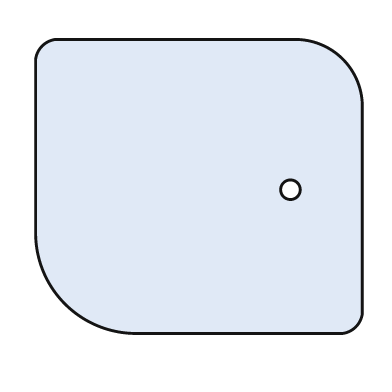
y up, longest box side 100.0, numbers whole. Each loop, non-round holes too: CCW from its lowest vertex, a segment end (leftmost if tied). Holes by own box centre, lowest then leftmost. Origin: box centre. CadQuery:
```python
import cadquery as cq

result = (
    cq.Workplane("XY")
    .moveTo(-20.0, -45.0)
    .lineTo(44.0, -45.0)
    .threePointArc((48.0, -43.0), (50.0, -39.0))
    .lineTo(50.0, 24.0)
    .threePointArc((44.0, 39.0), (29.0, 45.0))
    .lineTo(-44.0, 45.0)
    .threePointArc((-48.0, 43.0), (-50.0, 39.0))
    .lineTo(-50.0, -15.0)
    .threePointArc((-41.0, -36.0), (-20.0, -45.0))
    .close()
    .moveTo(28.0, -1.0)
    .circle(3.0)
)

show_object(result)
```